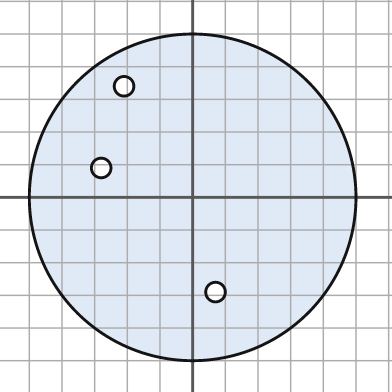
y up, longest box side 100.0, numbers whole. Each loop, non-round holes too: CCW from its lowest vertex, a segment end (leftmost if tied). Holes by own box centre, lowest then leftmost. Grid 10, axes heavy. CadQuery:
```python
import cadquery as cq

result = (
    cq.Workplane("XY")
    .moveTo(0.0, 0.0)
    .circle(50.0)
    .moveTo(7.0, -29.0)
    .circle(3.0)
    .moveTo(-28.0, 9.0)
    .circle(3.0)
    .moveTo(-21.0, 34.0)
    .circle(3.0)
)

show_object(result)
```